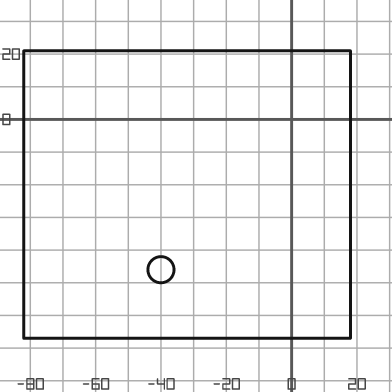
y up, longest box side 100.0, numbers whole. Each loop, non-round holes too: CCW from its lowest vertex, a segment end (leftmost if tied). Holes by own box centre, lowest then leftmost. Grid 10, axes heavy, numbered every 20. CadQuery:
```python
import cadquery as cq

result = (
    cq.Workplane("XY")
    .moveTo(-82.0, -67.0)
    .lineTo(18.0, -67.0)
    .lineTo(18.0, 21.0)
    .lineTo(-82.0, 21.0)
    .close()
    .moveTo(-40.0, -46.0)
    .circle(4.0)
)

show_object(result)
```